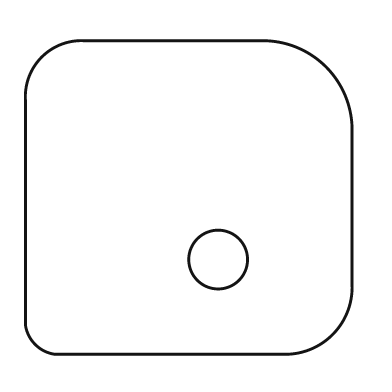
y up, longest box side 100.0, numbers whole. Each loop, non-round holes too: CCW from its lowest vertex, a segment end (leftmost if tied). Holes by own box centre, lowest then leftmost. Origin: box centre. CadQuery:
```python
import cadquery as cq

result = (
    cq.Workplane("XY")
    .moveTo(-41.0, -48.0)
    .lineTo(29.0, -48.0)
    .threePointArc((44.0, -42.0), (50.0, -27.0))
    .lineTo(50.0, 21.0)
    .threePointArc((42.0, 40.0), (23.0, 48.0))
    .lineTo(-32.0, 48.0)
    .threePointArc((-45.0, 43.0), (-50.0, 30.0))
    .lineTo(-50.0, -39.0)
    .threePointArc((-47.0, -45.0), (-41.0, -48.0))
    .close()
    .moveTo(9.0, -19.0)
    .circle(9.0)
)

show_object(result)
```